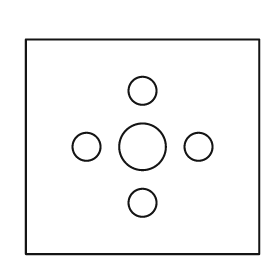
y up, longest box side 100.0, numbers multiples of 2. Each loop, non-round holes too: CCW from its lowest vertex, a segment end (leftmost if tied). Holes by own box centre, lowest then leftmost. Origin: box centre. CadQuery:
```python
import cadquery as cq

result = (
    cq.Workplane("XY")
    .moveTo(-50.0, -46.0)
    .lineTo(50.0, -46.0)
    .lineTo(50.0, 46.0)
    .lineTo(-50.0, 46.0)
    .close()
    .moveTo(0.0, -24.0)
    .circle(6.0)
    .moveTo(-24.0, 0.0)
    .circle(6.0)
    .moveTo(0.0, 0.0)
    .circle(10.0)
    .moveTo(24.0, 0.0)
    .circle(6.0)
    .moveTo(0.0, 24.0)
    .circle(6.0)
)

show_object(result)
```